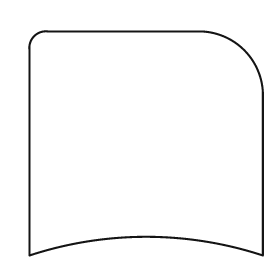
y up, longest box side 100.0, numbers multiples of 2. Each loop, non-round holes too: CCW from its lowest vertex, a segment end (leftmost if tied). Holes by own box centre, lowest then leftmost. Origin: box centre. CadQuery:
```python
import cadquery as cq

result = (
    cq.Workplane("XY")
    .moveTo(-50.0, -48.0)
    .threePointArc((0.0, -40.0), (50.0, -48.0))
    .lineTo(50.0, 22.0)
    .threePointArc((42.0, 40.0), (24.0, 48.0))
    .lineTo(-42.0, 48.0)
    .threePointArc((-48.0, 46.0), (-50.0, 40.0))
    .close()
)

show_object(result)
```